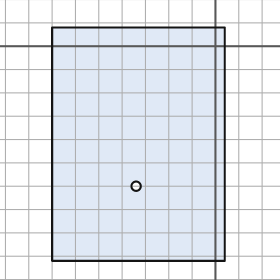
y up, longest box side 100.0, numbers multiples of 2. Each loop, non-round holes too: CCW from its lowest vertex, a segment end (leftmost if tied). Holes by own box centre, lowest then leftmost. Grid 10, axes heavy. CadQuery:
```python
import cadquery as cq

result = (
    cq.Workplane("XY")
    .moveTo(-70.0, -92.0)
    .lineTo(4.0, -92.0)
    .lineTo(4.0, 8.0)
    .lineTo(-70.0, 8.0)
    .close()
    .moveTo(-34.0, -60.0)
    .circle(2.0)
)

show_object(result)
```